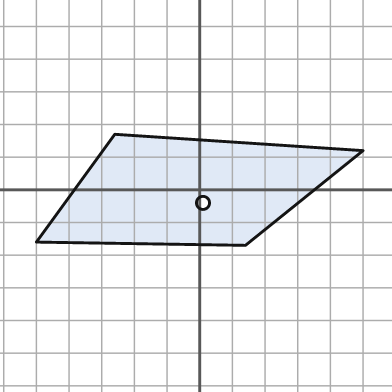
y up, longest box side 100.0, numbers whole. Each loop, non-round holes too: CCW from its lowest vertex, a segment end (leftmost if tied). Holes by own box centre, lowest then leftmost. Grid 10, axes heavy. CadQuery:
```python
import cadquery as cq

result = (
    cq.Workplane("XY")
    .moveTo(14.0, -17.0)
    .lineTo(50.0, 12.0)
    .lineTo(-26.0, 17.0)
    .lineTo(-50.0, -16.0)
    .close()
    .moveTo(1.0, -4.0)
    .circle(2.0)
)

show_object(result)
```